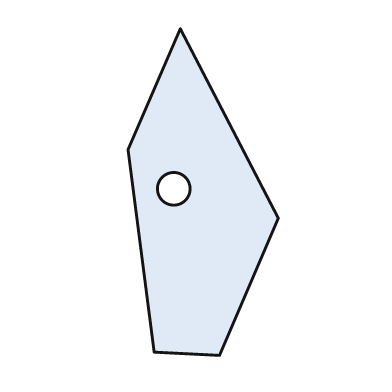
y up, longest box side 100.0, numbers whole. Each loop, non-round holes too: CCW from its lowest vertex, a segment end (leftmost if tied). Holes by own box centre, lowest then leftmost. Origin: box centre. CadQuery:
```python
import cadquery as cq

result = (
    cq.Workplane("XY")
    .moveTo(5.0, -50.0)
    .lineTo(23.0, -8.0)
    .lineTo(-7.0, 50.0)
    .lineTo(-23.0, 13.0)
    .lineTo(-15.0, -49.0)
    .close()
    .moveTo(-9.0, 1.0)
    .circle(5.0)
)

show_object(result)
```